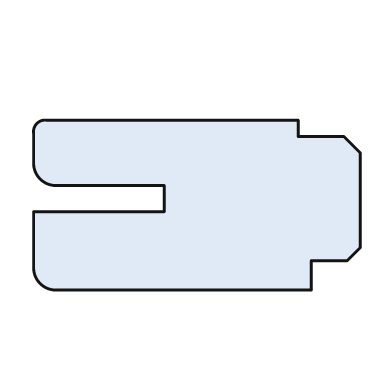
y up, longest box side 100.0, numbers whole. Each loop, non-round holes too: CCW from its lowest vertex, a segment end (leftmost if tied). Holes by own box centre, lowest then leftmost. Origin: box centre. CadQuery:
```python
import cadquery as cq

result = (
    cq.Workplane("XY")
    .moveTo(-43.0, -26.0)
    .lineTo(35.0, -26.0)
    .lineTo(35.0, -17.0)
    .lineTo(46.0, -17.0)
    .lineTo(50.0, -13.0)
    .lineTo(50.0, 16.0)
    .lineTo(45.0, 21.0)
    .lineTo(31.0, 21.0)
    .lineTo(31.0, 26.0)
    .lineTo(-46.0, 26.0)
    .threePointArc((-49.0, 25.0), (-50.0, 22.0))
    .lineTo(-50.0, 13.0)
    .threePointArc((-48.0, 8.0), (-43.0, 6.0))
    .lineTo(-10.0, 6.0)
    .lineTo(-10.0, -2.0)
    .lineTo(-50.0, -2.0)
    .lineTo(-50.0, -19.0)
    .threePointArc((-48.0, -24.0), (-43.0, -26.0))
    .close()
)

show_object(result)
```